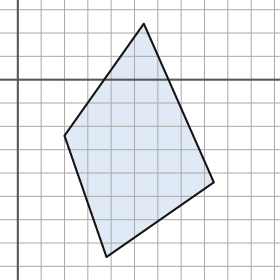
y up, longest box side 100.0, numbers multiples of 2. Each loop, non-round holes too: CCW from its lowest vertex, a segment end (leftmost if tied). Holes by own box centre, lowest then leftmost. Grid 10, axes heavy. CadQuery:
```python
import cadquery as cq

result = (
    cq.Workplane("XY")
    .moveTo(38.0, -76.0)
    .lineTo(84.0, -44.0)
    .lineTo(54.0, 24.0)
    .lineTo(20.0, -24.0)
    .close()
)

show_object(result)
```